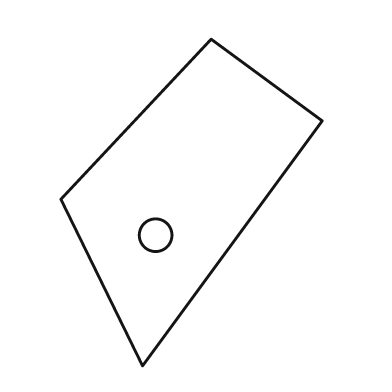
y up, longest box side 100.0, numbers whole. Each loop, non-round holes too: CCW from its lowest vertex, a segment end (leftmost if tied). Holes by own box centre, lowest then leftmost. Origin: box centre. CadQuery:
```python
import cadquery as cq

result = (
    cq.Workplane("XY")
    .moveTo(-15.0, -50.0)
    .lineTo(40.0, 25.0)
    .lineTo(6.0, 50.0)
    .lineTo(-40.0, 1.0)
    .close()
    .moveTo(-11.0, -10.0)
    .circle(5.0)
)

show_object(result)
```